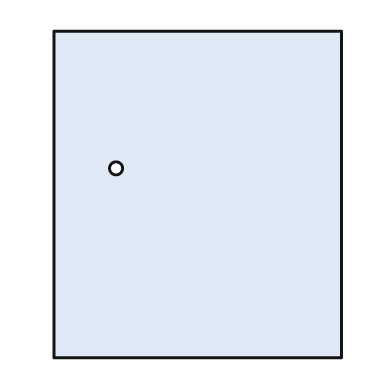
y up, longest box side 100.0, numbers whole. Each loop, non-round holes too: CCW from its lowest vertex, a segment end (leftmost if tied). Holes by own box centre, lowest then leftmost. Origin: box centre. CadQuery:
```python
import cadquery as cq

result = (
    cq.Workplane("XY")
    .moveTo(-44.0, -50.0)
    .lineTo(44.0, -50.0)
    .lineTo(44.0, 50.0)
    .lineTo(-44.0, 50.0)
    .close()
    .moveTo(-25.0, 8.0)
    .circle(2.0)
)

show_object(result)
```